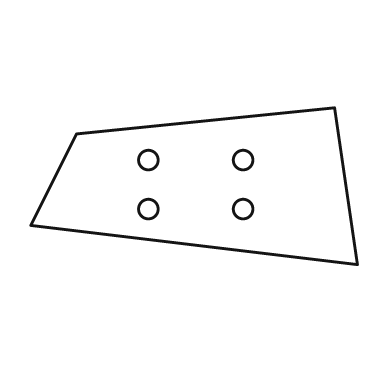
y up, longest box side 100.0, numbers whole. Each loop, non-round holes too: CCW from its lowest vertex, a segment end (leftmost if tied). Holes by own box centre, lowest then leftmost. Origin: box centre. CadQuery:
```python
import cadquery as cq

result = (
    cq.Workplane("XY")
    .moveTo(50.0, -24.0)
    .lineTo(43.0, 24.0)
    .lineTo(-36.0, 16.0)
    .lineTo(-50.0, -12.0)
    .close()
    .moveTo(-14.0, -7.0)
    .circle(3.0)
    .moveTo(15.0, -7.0)
    .circle(3.0)
    .moveTo(-14.0, 8.0)
    .circle(3.0)
    .moveTo(15.0, 8.0)
    .circle(3.0)
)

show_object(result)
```